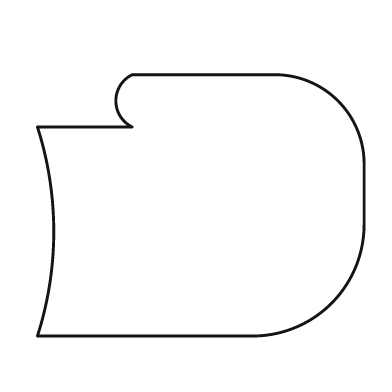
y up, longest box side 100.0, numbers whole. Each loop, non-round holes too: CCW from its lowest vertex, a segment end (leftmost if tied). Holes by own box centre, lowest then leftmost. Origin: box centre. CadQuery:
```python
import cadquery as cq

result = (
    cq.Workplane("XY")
    .moveTo(-50.0, -40.0)
    .lineTo(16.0, -40.0)
    .threePointArc((40.0, -30.0), (50.0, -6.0))
    .lineTo(50.0, 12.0)
    .threePointArc((42.0, 32.0), (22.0, 40.0))
    .lineTo(-21.0, 40.0)
    .threePointArc((-26.0, 32.0), (-21.0, 24.0))
    .lineTo(-50.0, 24.0)
    .threePointArc((-45.0, -8.0), (-50.0, -40.0))
    .close()
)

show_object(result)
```